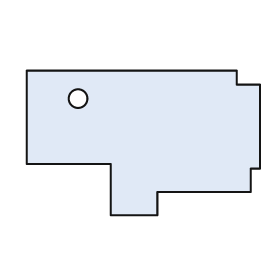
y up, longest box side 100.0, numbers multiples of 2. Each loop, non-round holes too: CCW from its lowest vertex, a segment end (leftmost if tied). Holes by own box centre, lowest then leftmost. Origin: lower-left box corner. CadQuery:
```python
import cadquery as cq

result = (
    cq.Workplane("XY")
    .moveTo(36.0, 0.0)
    .lineTo(56.0, 0.0)
    .lineTo(56.0, 10.0)
    .lineTo(96.0, 10.0)
    .lineTo(96.0, 20.0)
    .lineTo(100.0, 20.0)
    .lineTo(100.0, 56.0)
    .lineTo(90.0, 56.0)
    .lineTo(90.0, 62.0)
    .lineTo(0.0, 62.0)
    .lineTo(0.0, 22.0)
    .lineTo(36.0, 22.0)
    .close()
    .moveTo(22.0, 50.0)
    .circle(4.0)
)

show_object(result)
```